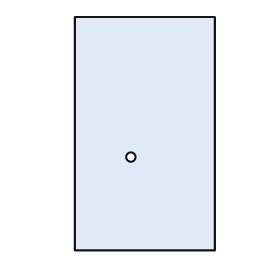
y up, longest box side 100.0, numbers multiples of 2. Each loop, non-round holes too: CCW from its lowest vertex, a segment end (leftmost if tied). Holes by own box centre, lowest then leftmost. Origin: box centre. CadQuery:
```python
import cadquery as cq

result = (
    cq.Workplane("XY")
    .moveTo(-30.0, -50.0)
    .lineTo(30.0, -50.0)
    .lineTo(30.0, 50.0)
    .lineTo(-30.0, 50.0)
    .close()
    .moveTo(-6.0, -10.0)
    .circle(2.0)
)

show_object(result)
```